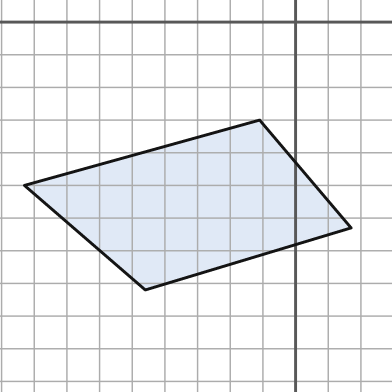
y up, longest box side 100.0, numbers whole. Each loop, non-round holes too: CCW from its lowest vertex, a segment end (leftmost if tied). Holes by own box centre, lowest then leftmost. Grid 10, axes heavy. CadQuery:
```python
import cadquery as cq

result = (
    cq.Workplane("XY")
    .moveTo(-46.0, -82.0)
    .lineTo(17.0, -63.0)
    .lineTo(-11.0, -30.0)
    .lineTo(-83.0, -50.0)
    .close()
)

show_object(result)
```